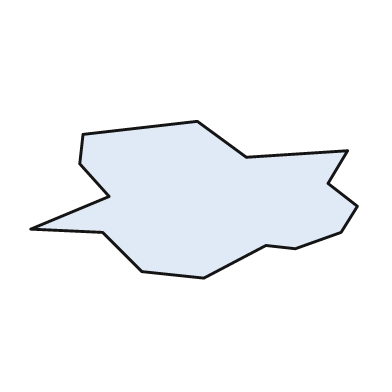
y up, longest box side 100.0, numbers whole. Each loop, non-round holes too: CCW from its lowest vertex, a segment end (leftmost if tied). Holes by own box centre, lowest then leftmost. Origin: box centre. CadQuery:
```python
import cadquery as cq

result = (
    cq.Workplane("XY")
    .moveTo(3.0, -24.0)
    .lineTo(22.0, -14.0)
    .lineTo(31.0, -15.0)
    .lineTo(45.0, -10.0)
    .lineTo(50.0, -2.0)
    .lineTo(41.0, 5.0)
    .lineTo(47.0, 15.0)
    .lineTo(16.0, 13.0)
    .lineTo(1.0, 24.0)
    .lineTo(-34.0, 20.0)
    .lineTo(-35.0, 11.0)
    .lineTo(-26.0, 1.0)
    .lineTo(-50.0, -9.0)
    .lineTo(-28.0, -10.0)
    .lineTo(-16.0, -22.0)
    .close()
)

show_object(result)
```